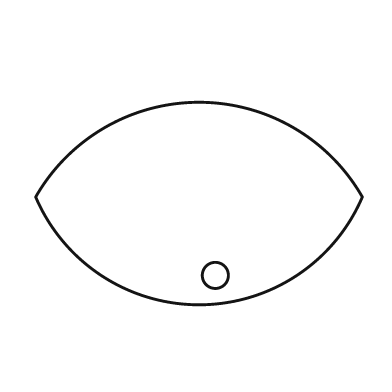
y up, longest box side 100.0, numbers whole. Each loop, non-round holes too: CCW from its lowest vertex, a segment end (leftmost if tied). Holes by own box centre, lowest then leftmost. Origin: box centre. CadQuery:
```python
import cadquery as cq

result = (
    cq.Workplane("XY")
    .moveTo(-50.0, 2.0)
    .threePointArc((0.0, -31.0), (50.0, 2.0))
    .threePointArc((0.0, 31.0), (-50.0, 2.0))
    .close()
    .moveTo(5.0, -22.0)
    .circle(4.0)
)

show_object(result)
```